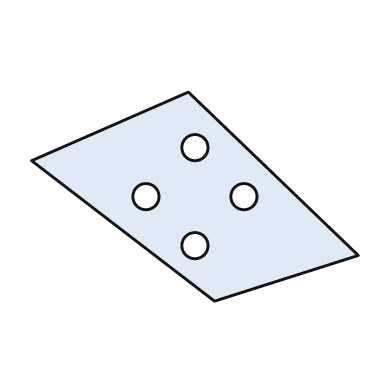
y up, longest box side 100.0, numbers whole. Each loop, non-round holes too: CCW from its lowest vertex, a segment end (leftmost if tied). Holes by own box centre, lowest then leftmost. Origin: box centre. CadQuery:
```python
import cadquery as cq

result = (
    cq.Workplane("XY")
    .moveTo(6.0, -32.0)
    .lineTo(50.0, -18.0)
    .lineTo(-2.0, 32.0)
    .lineTo(-50.0, 11.0)
    .close()
    .moveTo(0.0, -15.0)
    .circle(4.0)
    .moveTo(-15.0, 0.0)
    .circle(4.0)
    .moveTo(15.0, 0.0)
    .circle(4.0)
    .moveTo(0.0, 15.0)
    .circle(4.0)
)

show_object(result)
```